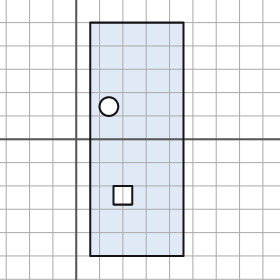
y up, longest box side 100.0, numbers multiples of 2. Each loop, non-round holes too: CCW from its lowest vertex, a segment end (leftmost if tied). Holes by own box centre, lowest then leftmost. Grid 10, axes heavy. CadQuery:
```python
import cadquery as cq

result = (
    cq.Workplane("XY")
    .moveTo(6.0, -50.0)
    .lineTo(46.0, -50.0)
    .lineTo(46.0, 50.0)
    .lineTo(6.0, 50.0)
    .close()
    .moveTo(16.0, -28.0)
    .lineTo(24.0, -28.0)
    .lineTo(24.0, -20.0)
    .lineTo(16.0, -20.0)
    .close()
    .moveTo(14.0, 14.0)
    .circle(4.0)
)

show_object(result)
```